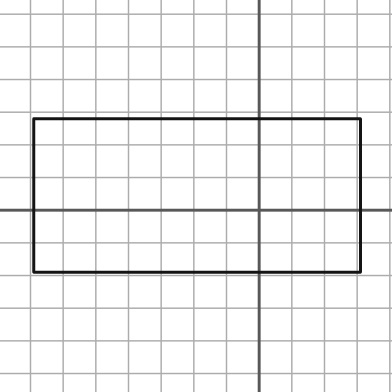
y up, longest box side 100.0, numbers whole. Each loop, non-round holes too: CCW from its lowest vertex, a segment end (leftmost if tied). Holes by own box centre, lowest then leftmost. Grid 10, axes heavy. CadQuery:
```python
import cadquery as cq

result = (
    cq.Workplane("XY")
    .moveTo(-69.0, -19.0)
    .lineTo(31.0, -19.0)
    .lineTo(31.0, 28.0)
    .lineTo(-69.0, 28.0)
    .close()
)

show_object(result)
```